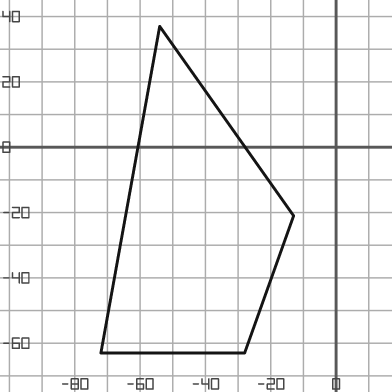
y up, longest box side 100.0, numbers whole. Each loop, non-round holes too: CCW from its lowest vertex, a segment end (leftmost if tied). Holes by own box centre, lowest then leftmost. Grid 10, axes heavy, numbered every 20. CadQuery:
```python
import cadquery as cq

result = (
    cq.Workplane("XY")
    .moveTo(-72.0, -63.0)
    .lineTo(-28.0, -63.0)
    .lineTo(-13.0, -21.0)
    .lineTo(-54.0, 37.0)
    .close()
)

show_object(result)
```